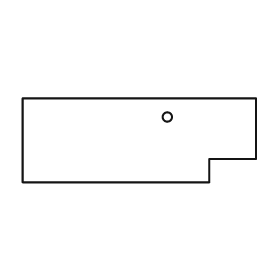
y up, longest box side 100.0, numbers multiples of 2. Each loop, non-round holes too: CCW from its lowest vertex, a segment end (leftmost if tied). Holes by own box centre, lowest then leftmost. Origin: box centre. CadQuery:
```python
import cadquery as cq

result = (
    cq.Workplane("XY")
    .moveTo(-50.0, -18.0)
    .lineTo(30.0, -18.0)
    .lineTo(30.0, -8.0)
    .lineTo(50.0, -8.0)
    .lineTo(50.0, 18.0)
    .lineTo(-50.0, 18.0)
    .close()
    .moveTo(12.0, 10.0)
    .circle(2.0)
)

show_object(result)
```